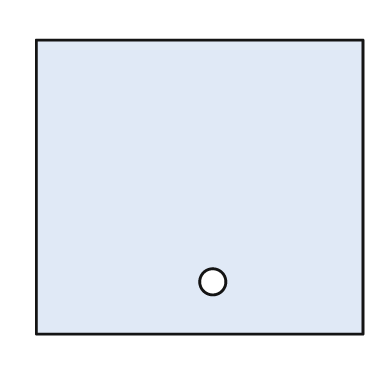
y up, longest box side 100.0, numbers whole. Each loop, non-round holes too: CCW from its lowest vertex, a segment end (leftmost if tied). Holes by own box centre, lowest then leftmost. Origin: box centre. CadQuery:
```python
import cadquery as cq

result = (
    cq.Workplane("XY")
    .moveTo(-50.0, -45.0)
    .lineTo(50.0, -45.0)
    .lineTo(50.0, 45.0)
    .lineTo(-50.0, 45.0)
    .close()
    .moveTo(4.0, -29.0)
    .circle(4.0)
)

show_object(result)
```